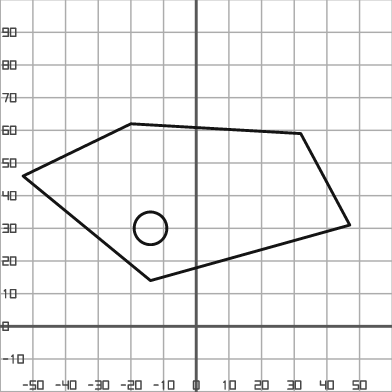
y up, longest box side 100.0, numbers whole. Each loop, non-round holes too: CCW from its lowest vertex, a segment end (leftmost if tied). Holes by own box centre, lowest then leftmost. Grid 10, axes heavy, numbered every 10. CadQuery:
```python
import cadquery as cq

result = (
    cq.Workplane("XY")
    .moveTo(-14.0, 14.0)
    .lineTo(47.0, 31.0)
    .lineTo(32.0, 59.0)
    .lineTo(-20.0, 62.0)
    .lineTo(-53.0, 46.0)
    .close()
    .moveTo(-14.0, 30.0)
    .circle(5.0)
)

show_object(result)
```